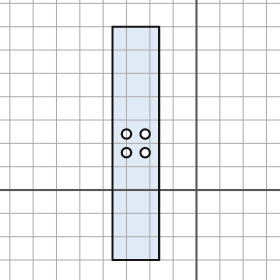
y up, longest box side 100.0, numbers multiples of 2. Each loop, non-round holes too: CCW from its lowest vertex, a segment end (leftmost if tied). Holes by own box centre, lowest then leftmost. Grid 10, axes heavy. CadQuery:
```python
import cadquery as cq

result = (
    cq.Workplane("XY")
    .moveTo(-36.0, -30.0)
    .lineTo(-16.0, -30.0)
    .lineTo(-16.0, 70.0)
    .lineTo(-36.0, 70.0)
    .close()
    .moveTo(-30.0, 16.0)
    .circle(2.0)
    .moveTo(-22.0, 16.0)
    .circle(2.0)
    .moveTo(-30.0, 24.0)
    .circle(2.0)
    .moveTo(-22.0, 24.0)
    .circle(2.0)
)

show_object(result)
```